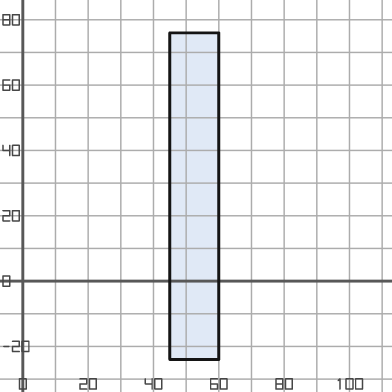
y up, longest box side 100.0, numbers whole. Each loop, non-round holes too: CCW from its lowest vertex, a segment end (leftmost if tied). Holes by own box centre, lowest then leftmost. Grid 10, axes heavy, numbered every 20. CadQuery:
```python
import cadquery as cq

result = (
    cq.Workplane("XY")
    .moveTo(45.0, -24.0)
    .lineTo(60.0, -24.0)
    .lineTo(60.0, 76.0)
    .lineTo(45.0, 76.0)
    .close()
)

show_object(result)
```